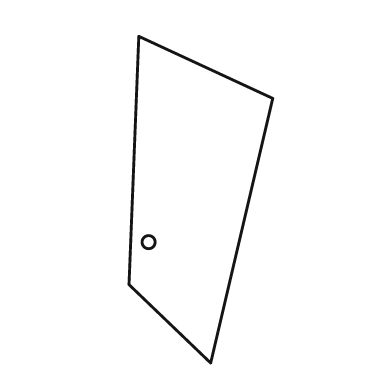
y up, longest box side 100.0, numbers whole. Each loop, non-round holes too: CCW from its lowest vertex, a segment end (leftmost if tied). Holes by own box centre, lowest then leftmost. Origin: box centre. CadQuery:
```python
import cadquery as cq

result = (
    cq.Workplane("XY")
    .moveTo(3.0, -50.0)
    .lineTo(22.0, 31.0)
    .lineTo(-19.0, 50.0)
    .lineTo(-22.0, -26.0)
    .close()
    .moveTo(-16.0, -13.0)
    .circle(2.0)
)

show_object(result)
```